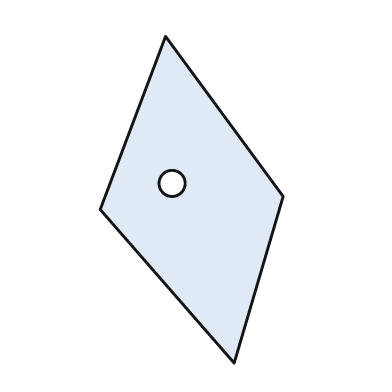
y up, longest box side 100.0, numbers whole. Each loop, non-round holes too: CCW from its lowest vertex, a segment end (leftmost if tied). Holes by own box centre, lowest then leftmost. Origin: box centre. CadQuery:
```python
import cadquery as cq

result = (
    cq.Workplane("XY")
    .moveTo(13.0, -50.0)
    .lineTo(28.0, 1.0)
    .lineTo(-8.0, 50.0)
    .lineTo(-28.0, -3.0)
    .close()
    .moveTo(-6.0, 5.0)
    .circle(4.0)
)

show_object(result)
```